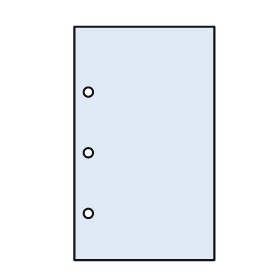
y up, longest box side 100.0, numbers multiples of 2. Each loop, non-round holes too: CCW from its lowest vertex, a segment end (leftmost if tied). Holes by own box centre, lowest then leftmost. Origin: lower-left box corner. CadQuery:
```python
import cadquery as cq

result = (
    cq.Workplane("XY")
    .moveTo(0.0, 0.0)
    .lineTo(60.0, 0.0)
    .lineTo(60.0, 100.0)
    .lineTo(0.0, 100.0)
    .close()
    .moveTo(6.0, 20.0)
    .circle(2.0)
    .moveTo(6.0, 46.0)
    .circle(2.0)
    .moveTo(6.0, 72.0)
    .circle(2.0)
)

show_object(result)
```